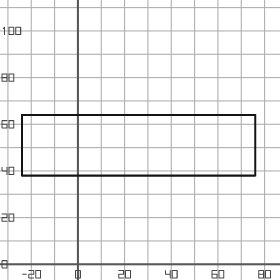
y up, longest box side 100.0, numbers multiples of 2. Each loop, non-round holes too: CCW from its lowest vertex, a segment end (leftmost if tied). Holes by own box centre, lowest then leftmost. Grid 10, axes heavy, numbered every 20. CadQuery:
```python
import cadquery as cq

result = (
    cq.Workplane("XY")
    .moveTo(-24.0, 38.0)
    .lineTo(76.0, 38.0)
    .lineTo(76.0, 64.0)
    .lineTo(-24.0, 64.0)
    .close()
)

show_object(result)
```